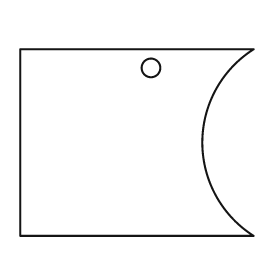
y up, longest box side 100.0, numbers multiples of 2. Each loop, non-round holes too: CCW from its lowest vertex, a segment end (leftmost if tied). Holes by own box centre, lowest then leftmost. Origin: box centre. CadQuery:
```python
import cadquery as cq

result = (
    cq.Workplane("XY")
    .moveTo(-50.0, -40.0)
    .lineTo(50.0, -40.0)
    .threePointArc((28.0, 0.0), (50.0, 40.0))
    .lineTo(-50.0, 40.0)
    .close()
    .moveTo(6.0, 32.0)
    .circle(4.0)
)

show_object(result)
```